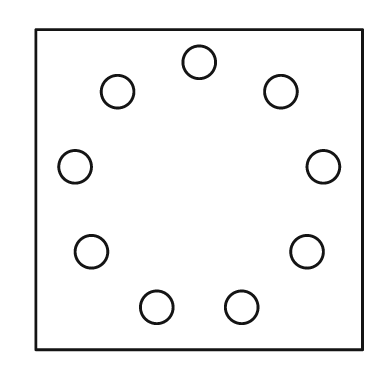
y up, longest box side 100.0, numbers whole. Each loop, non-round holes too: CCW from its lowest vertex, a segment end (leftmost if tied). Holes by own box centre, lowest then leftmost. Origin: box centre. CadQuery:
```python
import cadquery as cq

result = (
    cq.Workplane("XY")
    .moveTo(-50.0, -49.0)
    .lineTo(50.0, -49.0)
    .lineTo(50.0, 49.0)
    .lineTo(-50.0, 49.0)
    .close()
    .moveTo(-13.0, -36.0)
    .circle(5.0)
    .moveTo(13.0, -36.0)
    .circle(5.0)
    .moveTo(-33.0, -19.0)
    .circle(5.0)
    .moveTo(33.0, -19.0)
    .circle(5.0)
    .moveTo(-38.0, 7.0)
    .circle(5.0)
    .moveTo(38.0, 7.0)
    .circle(5.0)
    .moveTo(-25.0, 30.0)
    .circle(5.0)
    .moveTo(25.0, 30.0)
    .circle(5.0)
    .moveTo(0.0, 39.0)
    .circle(5.0)
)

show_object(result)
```